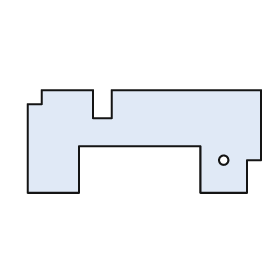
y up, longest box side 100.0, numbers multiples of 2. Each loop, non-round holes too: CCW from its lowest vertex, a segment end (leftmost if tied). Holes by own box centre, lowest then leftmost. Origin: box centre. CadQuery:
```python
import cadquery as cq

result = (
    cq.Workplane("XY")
    .moveTo(-50.0, -22.0)
    .lineTo(-28.0, -22.0)
    .lineTo(-28.0, -2.0)
    .lineTo(24.0, -2.0)
    .lineTo(24.0, -22.0)
    .lineTo(44.0, -22.0)
    .lineTo(44.0, -8.0)
    .lineTo(50.0, -8.0)
    .lineTo(50.0, 22.0)
    .lineTo(-14.0, 22.0)
    .lineTo(-14.0, 10.0)
    .lineTo(-22.0, 10.0)
    .lineTo(-22.0, 22.0)
    .lineTo(-44.0, 22.0)
    .lineTo(-44.0, 16.0)
    .lineTo(-50.0, 16.0)
    .close()
    .moveTo(34.0, -8.0)
    .circle(2.0)
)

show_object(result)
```